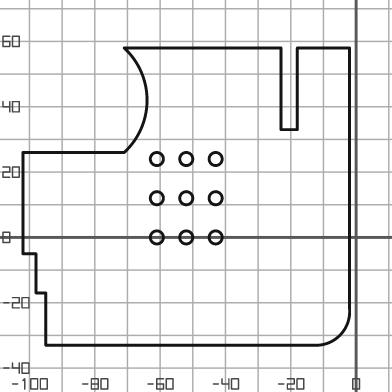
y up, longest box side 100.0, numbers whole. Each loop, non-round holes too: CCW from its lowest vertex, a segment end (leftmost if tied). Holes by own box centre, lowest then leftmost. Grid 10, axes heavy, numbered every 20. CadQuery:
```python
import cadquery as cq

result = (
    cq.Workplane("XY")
    .moveTo(-95.0, -33.0)
    .lineTo(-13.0, -33.0)
    .threePointArc((-5.0, -30.0), (-2.0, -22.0))
    .lineTo(-2.0, 58.0)
    .lineTo(-18.0, 58.0)
    .lineTo(-18.0, 33.0)
    .lineTo(-23.0, 33.0)
    .lineTo(-23.0, 58.0)
    .lineTo(-71.0, 58.0)
    .threePointArc((-64.0, 42.0), (-71.0, 26.0))
    .lineTo(-102.0, 26.0)
    .lineTo(-102.0, -5.0)
    .lineTo(-98.0, -5.0)
    .lineTo(-98.0, -17.0)
    .lineTo(-95.0, -17.0)
    .close()
    .moveTo(-61.0, 0.0)
    .circle(2.0)
    .moveTo(-52.0, 0.0)
    .circle(2.0)
    .moveTo(-43.0, 0.0)
    .circle(2.0)
    .moveTo(-61.0, 12.0)
    .circle(2.0)
    .moveTo(-52.0, 12.0)
    .circle(2.0)
    .moveTo(-43.0, 12.0)
    .circle(2.0)
    .moveTo(-61.0, 24.0)
    .circle(2.0)
    .moveTo(-52.0, 24.0)
    .circle(2.0)
    .moveTo(-43.0, 24.0)
    .circle(2.0)
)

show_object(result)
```